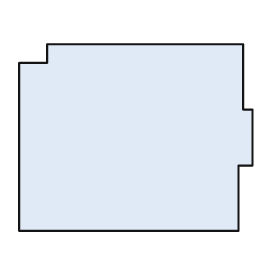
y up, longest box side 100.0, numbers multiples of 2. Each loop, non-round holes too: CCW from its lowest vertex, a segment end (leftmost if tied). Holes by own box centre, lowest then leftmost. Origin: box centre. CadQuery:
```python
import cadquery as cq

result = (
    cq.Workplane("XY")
    .moveTo(-50.0, -40.0)
    .lineTo(44.0, -40.0)
    .lineTo(44.0, -12.0)
    .lineTo(50.0, -12.0)
    .lineTo(50.0, 12.0)
    .lineTo(46.0, 12.0)
    .lineTo(46.0, 40.0)
    .lineTo(-38.0, 40.0)
    .lineTo(-38.0, 32.0)
    .lineTo(-50.0, 32.0)
    .close()
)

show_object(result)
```